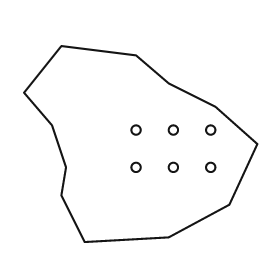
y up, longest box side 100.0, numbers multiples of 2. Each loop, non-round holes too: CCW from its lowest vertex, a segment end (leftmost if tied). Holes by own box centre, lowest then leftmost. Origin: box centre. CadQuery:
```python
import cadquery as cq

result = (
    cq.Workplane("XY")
    .moveTo(-24.0, -42.0)
    .lineTo(12.0, -40.0)
    .lineTo(38.0, -26.0)
    .lineTo(50.0, 0.0)
    .lineTo(32.0, 16.0)
    .lineTo(12.0, 26.0)
    .lineTo(-2.0, 38.0)
    .lineTo(-34.0, 42.0)
    .lineTo(-50.0, 22.0)
    .lineTo(-38.0, 8.0)
    .lineTo(-32.0, -10.0)
    .lineTo(-34.0, -22.0)
    .close()
    .moveTo(-2.0, -10.0)
    .circle(2.0)
    .moveTo(14.0, -10.0)
    .circle(2.0)
    .moveTo(30.0, -10.0)
    .circle(2.0)
    .moveTo(-2.0, 6.0)
    .circle(2.0)
    .moveTo(14.0, 6.0)
    .circle(2.0)
    .moveTo(30.0, 6.0)
    .circle(2.0)
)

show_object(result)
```